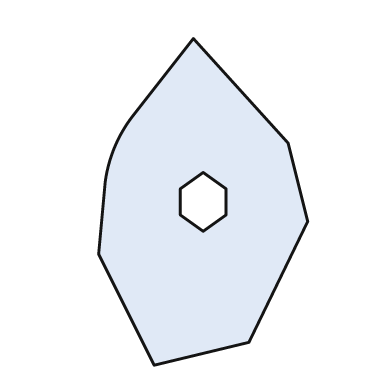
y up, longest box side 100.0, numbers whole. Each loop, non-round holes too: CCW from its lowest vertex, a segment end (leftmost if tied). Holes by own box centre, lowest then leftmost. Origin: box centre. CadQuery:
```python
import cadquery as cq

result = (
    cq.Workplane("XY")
    .moveTo(-15.0, -50.0)
    .lineTo(14.0, -43.0)
    .lineTo(32.0, -6.0)
    .lineTo(26.0, 18.0)
    .lineTo(-3.0, 50.0)
    .lineTo(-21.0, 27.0)
    .threePointArc((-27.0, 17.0), (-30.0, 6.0))
    .lineTo(-32.0, -16.0)
    .close()
    .moveTo(0.0, -9.0)
    .lineTo(7.0, -4.0)
    .lineTo(7.0, 4.0)
    .lineTo(0.0, 9.0)
    .lineTo(-7.0, 4.0)
    .lineTo(-7.0, -4.0)
    .close()
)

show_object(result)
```